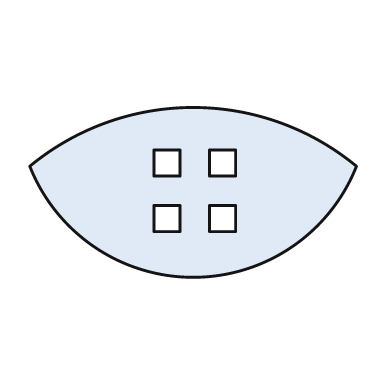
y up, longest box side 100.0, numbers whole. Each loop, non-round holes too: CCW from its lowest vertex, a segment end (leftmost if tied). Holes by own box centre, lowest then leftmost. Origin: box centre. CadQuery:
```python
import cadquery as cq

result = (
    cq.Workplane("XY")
    .moveTo(-50.0, 8.0)
    .threePointArc((0.0, -26.0), (50.0, 8.0))
    .threePointArc((0.0, 26.0), (-50.0, 8.0))
    .close()
    .moveTo(-12.0, -12.0)
    .lineTo(-4.0, -12.0)
    .lineTo(-4.0, -4.0)
    .lineTo(-12.0, -4.0)
    .close()
    .moveTo(5.0, -12.0)
    .lineTo(13.0, -12.0)
    .lineTo(13.0, -4.0)
    .lineTo(5.0, -4.0)
    .close()
    .moveTo(-12.0, 5.0)
    .lineTo(-4.0, 5.0)
    .lineTo(-4.0, 13.0)
    .lineTo(-12.0, 13.0)
    .close()
    .moveTo(5.0, 5.0)
    .lineTo(13.0, 5.0)
    .lineTo(13.0, 13.0)
    .lineTo(5.0, 13.0)
    .close()
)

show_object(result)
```